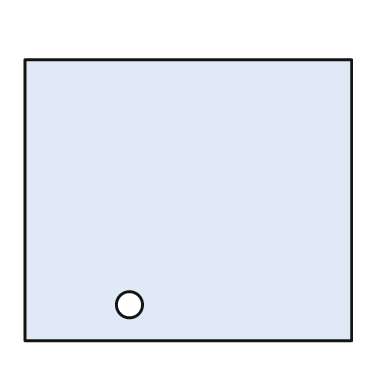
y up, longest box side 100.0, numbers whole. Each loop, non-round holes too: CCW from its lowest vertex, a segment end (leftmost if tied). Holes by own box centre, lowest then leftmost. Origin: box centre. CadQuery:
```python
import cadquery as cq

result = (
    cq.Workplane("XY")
    .moveTo(-50.0, -43.0)
    .lineTo(50.0, -43.0)
    .lineTo(50.0, 43.0)
    .lineTo(-50.0, 43.0)
    .close()
    .moveTo(-18.0, -32.0)
    .circle(4.0)
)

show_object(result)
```